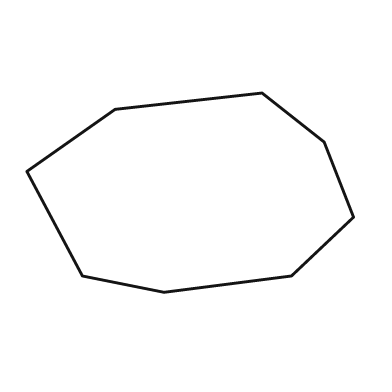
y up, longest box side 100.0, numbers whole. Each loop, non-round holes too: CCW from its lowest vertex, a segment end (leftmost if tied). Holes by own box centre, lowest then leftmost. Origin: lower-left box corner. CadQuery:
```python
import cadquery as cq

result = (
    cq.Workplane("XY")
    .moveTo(42.0, 0.0)
    .lineTo(81.0, 5.0)
    .lineTo(100.0, 23.0)
    .lineTo(91.0, 46.0)
    .lineTo(72.0, 61.0)
    .lineTo(27.0, 56.0)
    .lineTo(0.0, 37.0)
    .lineTo(17.0, 5.0)
    .close()
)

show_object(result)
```